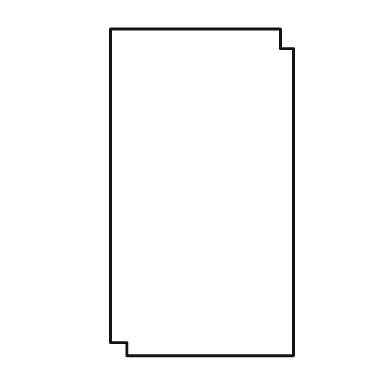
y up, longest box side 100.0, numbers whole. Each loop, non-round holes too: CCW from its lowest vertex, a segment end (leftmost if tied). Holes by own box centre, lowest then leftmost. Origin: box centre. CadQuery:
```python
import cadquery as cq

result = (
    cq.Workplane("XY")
    .moveTo(-23.0, -50.0)
    .lineTo(28.0, -50.0)
    .lineTo(28.0, 44.0)
    .lineTo(24.0, 44.0)
    .lineTo(24.0, 50.0)
    .lineTo(-28.0, 50.0)
    .lineTo(-28.0, -46.0)
    .lineTo(-23.0, -46.0)
    .close()
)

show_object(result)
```